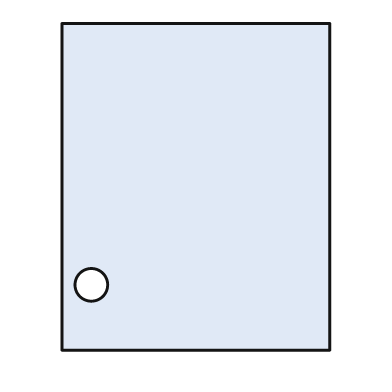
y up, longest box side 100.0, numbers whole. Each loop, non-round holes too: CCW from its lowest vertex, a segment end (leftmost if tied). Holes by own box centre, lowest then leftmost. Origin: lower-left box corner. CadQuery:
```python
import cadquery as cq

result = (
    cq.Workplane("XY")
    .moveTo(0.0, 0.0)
    .lineTo(82.0, 0.0)
    .lineTo(82.0, 100.0)
    .lineTo(0.0, 100.0)
    .close()
    .moveTo(9.0, 20.0)
    .circle(5.0)
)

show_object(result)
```